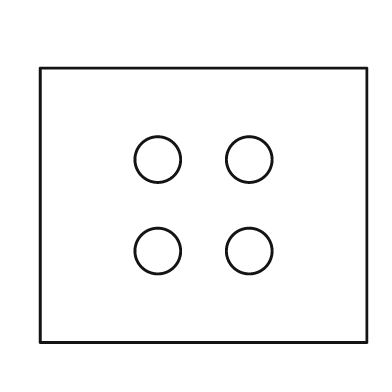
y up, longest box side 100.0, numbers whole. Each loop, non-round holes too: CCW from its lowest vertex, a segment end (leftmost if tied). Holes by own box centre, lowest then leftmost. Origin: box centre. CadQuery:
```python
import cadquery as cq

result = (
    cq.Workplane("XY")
    .moveTo(-50.0, -42.0)
    .lineTo(50.0, -42.0)
    .lineTo(50.0, 42.0)
    .lineTo(-50.0, 42.0)
    .close()
    .moveTo(-14.0, -14.0)
    .circle(7.0)
    .moveTo(14.0, -14.0)
    .circle(7.0)
    .moveTo(-14.0, 14.0)
    .circle(7.0)
    .moveTo(14.0, 14.0)
    .circle(7.0)
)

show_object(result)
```